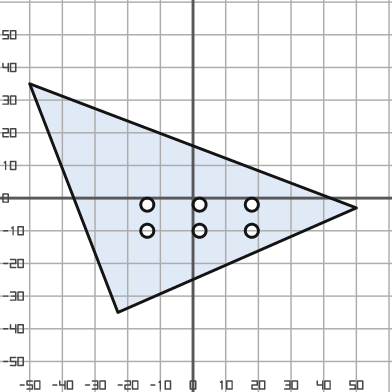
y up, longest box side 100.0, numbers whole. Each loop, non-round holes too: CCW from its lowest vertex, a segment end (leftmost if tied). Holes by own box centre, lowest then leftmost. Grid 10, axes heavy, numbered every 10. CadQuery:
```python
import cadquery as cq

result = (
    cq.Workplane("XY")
    .moveTo(-23.0, -35.0)
    .lineTo(50.0, -3.0)
    .lineTo(-50.0, 35.0)
    .close()
    .moveTo(-14.0, -10.0)
    .circle(2.0)
    .moveTo(2.0, -10.0)
    .circle(2.0)
    .moveTo(18.0, -10.0)
    .circle(2.0)
    .moveTo(-14.0, -2.0)
    .circle(2.0)
    .moveTo(2.0, -2.0)
    .circle(2.0)
    .moveTo(18.0, -2.0)
    .circle(2.0)
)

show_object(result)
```